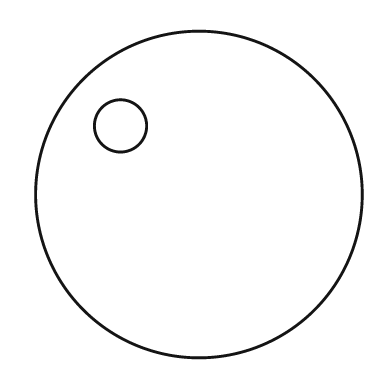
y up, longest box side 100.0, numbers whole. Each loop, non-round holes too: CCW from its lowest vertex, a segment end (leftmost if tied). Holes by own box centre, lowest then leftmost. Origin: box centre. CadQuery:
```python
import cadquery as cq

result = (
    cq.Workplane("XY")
    .moveTo(0.0, 0.0)
    .circle(50.0)
    .moveTo(-24.0, 21.0)
    .circle(8.0)
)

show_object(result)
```